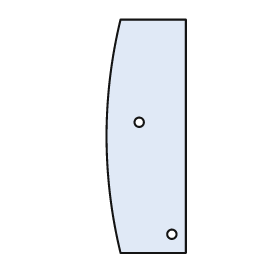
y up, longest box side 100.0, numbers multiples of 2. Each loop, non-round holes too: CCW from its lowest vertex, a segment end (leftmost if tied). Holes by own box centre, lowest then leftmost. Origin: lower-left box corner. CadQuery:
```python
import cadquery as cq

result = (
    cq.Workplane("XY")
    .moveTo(6.0, 0.0)
    .lineTo(34.0, 0.0)
    .lineTo(34.0, 100.0)
    .lineTo(6.0, 100.0)
    .threePointArc((0.0, 50.0), (6.0, 0.0))
    .close()
    .moveTo(28.0, 8.0)
    .circle(2.0)
    .moveTo(14.0, 56.0)
    .circle(2.0)
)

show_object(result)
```